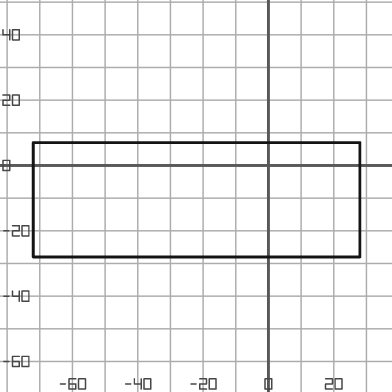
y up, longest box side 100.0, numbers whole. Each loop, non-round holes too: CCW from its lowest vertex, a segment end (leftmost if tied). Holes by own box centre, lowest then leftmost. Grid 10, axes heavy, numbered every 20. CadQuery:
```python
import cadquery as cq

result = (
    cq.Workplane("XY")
    .moveTo(-72.0, -28.0)
    .lineTo(28.0, -28.0)
    .lineTo(28.0, 7.0)
    .lineTo(-72.0, 7.0)
    .close()
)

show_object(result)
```